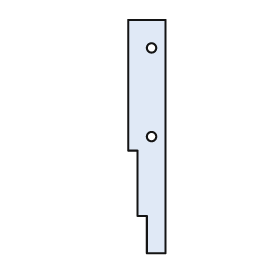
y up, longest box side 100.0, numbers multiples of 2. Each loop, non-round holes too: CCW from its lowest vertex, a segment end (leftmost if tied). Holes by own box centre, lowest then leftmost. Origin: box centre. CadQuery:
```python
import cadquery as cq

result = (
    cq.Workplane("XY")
    .moveTo(0.0, -50.0)
    .lineTo(8.0, -50.0)
    .lineTo(8.0, 50.0)
    .lineTo(-8.0, 50.0)
    .lineTo(-8.0, -6.0)
    .lineTo(-4.0, -6.0)
    .lineTo(-4.0, -34.0)
    .lineTo(0.0, -34.0)
    .close()
    .moveTo(2.0, 0.0)
    .circle(2.0)
    .moveTo(2.0, 38.0)
    .circle(2.0)
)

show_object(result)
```